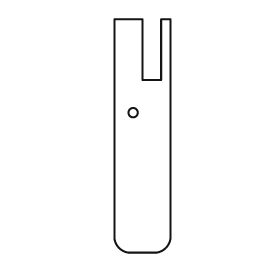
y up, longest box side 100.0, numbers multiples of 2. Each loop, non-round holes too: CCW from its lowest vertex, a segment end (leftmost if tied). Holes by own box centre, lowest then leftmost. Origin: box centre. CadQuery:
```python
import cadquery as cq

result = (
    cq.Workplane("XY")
    .moveTo(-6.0, -50.0)
    .lineTo(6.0, -50.0)
    .threePointArc((10.0, -48.0), (12.0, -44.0))
    .lineTo(12.0, 50.0)
    .lineTo(8.0, 50.0)
    .lineTo(8.0, 24.0)
    .lineTo(0.0, 24.0)
    .lineTo(0.0, 50.0)
    .lineTo(-12.0, 50.0)
    .lineTo(-12.0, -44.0)
    .threePointArc((-10.0, -48.0), (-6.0, -50.0))
    .close()
    .moveTo(-4.0, 10.0)
    .circle(2.0)
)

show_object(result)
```